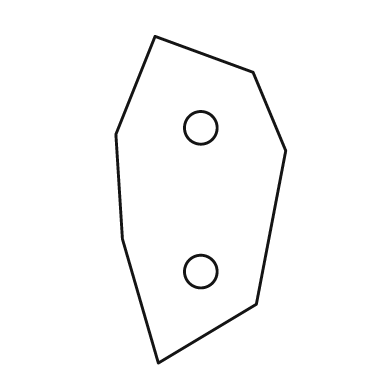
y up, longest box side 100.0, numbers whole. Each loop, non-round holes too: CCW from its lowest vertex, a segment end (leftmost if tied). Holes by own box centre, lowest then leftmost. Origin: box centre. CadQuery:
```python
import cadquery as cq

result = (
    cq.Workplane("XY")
    .moveTo(-13.0, -50.0)
    .lineTo(17.0, -32.0)
    .lineTo(26.0, 15.0)
    .lineTo(16.0, 39.0)
    .lineTo(-14.0, 50.0)
    .lineTo(-26.0, 20.0)
    .lineTo(-24.0, -12.0)
    .close()
    .moveTo(0.0, -22.0)
    .circle(5.0)
    .moveTo(0.0, 22.0)
    .circle(5.0)
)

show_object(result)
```